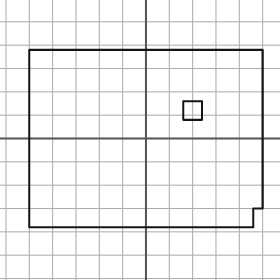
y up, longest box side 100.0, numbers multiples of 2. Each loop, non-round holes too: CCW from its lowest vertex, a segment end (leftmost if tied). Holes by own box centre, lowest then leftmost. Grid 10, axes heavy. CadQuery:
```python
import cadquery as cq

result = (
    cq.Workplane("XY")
    .moveTo(-50.0, -38.0)
    .lineTo(46.0, -38.0)
    .lineTo(46.0, -30.0)
    .lineTo(50.0, -30.0)
    .lineTo(50.0, 38.0)
    .lineTo(-50.0, 38.0)
    .close()
    .moveTo(16.0, 8.0)
    .lineTo(24.0, 8.0)
    .lineTo(24.0, 16.0)
    .lineTo(16.0, 16.0)
    .close()
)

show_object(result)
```